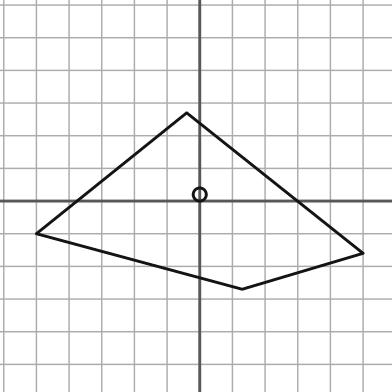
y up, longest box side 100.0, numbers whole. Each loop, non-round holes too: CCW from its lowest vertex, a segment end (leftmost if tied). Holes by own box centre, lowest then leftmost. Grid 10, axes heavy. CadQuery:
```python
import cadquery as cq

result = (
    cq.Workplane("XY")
    .moveTo(13.0, -27.0)
    .lineTo(50.0, -16.0)
    .lineTo(-4.0, 27.0)
    .lineTo(-50.0, -10.0)
    .close()
    .moveTo(0.0, 2.0)
    .circle(2.0)
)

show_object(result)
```